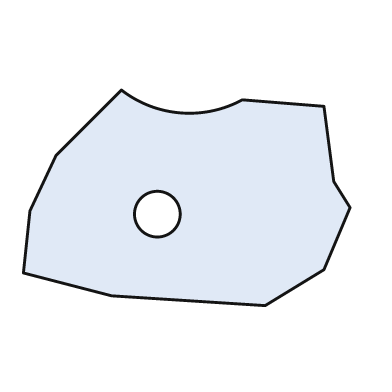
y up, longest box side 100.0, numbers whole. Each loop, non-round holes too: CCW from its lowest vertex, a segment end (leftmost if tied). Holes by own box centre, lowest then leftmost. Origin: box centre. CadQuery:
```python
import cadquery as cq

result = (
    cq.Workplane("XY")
    .moveTo(24.0, -33.0)
    .lineTo(42.0, -22.0)
    .lineTo(50.0, -3.0)
    .lineTo(45.0, 5.0)
    .lineTo(42.0, 28.0)
    .lineTo(17.0, 30.0)
    .threePointArc((-2.0, 26.0), (-20.0, 33.0))
    .lineTo(-40.0, 13.0)
    .lineTo(-48.0, -4.0)
    .lineTo(-50.0, -23.0)
    .lineTo(-23.0, -30.0)
    .close()
    .moveTo(-9.0, -5.0)
    .circle(7.0)
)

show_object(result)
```